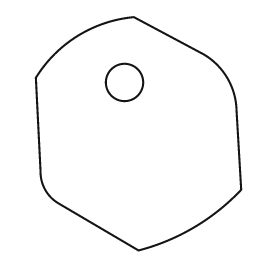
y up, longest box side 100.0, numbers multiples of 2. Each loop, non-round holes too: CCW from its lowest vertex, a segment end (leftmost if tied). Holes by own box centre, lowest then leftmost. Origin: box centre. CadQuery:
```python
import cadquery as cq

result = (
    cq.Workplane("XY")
    .moveTo(0.0, -50.0)
    .threePointArc((24.0, -40.0), (44.0, -24.0))
    .lineTo(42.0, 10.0)
    .threePointArc((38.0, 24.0), (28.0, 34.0))
    .lineTo(-2.0, 50.0)
    .threePointArc((-26.0, 42.0), (-44.0, 24.0))
    .lineTo(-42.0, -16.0)
    .threePointArc((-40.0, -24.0), (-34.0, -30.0))
    .close()
    .moveTo(-6.0, 22.0)
    .circle(8.0)
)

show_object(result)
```